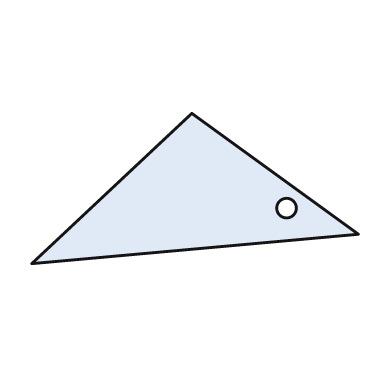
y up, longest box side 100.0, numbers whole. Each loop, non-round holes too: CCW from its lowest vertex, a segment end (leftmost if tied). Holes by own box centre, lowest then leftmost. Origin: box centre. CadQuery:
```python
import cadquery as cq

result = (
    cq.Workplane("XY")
    .moveTo(-50.0, -23.0)
    .lineTo(50.0, -14.0)
    .lineTo(-1.0, 23.0)
    .close()
    .moveTo(28.0, -6.0)
    .circle(3.0)
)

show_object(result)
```